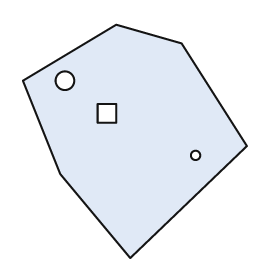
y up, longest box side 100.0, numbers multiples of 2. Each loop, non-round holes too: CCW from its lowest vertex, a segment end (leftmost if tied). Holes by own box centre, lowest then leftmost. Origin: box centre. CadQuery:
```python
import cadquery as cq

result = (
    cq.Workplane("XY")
    .moveTo(-2.0, -50.0)
    .lineTo(48.0, -2.0)
    .lineTo(20.0, 42.0)
    .lineTo(-8.0, 50.0)
    .lineTo(-48.0, 26.0)
    .lineTo(-32.0, -14.0)
    .close()
    .moveTo(26.0, -6.0)
    .circle(2.0)
    .moveTo(-16.0, 8.0)
    .lineTo(-8.0, 8.0)
    .lineTo(-8.0, 16.0)
    .lineTo(-16.0, 16.0)
    .close()
    .moveTo(-30.0, 26.0)
    .circle(4.0)
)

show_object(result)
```